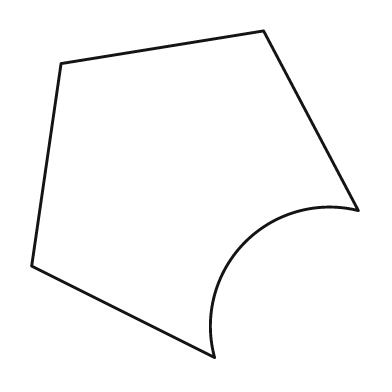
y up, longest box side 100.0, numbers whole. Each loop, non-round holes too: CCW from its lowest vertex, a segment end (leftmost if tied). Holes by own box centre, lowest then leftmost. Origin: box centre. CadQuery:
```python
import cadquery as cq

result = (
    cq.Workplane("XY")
    .moveTo(6.0, -50.0)
    .threePointArc((15.0, -15.0), (50.0, -5.0))
    .lineTo(21.0, 50.0)
    .lineTo(-41.0, 40.0)
    .lineTo(-50.0, -22.0)
    .close()
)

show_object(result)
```